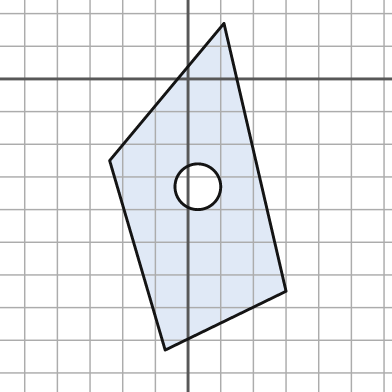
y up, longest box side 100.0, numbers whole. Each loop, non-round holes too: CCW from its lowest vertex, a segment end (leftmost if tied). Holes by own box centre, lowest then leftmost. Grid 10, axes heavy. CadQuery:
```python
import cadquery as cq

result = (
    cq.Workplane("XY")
    .moveTo(-7.0, -83.0)
    .lineTo(30.0, -65.0)
    .lineTo(11.0, 17.0)
    .lineTo(-24.0, -25.0)
    .close()
    .moveTo(3.0, -33.0)
    .circle(7.0)
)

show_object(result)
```